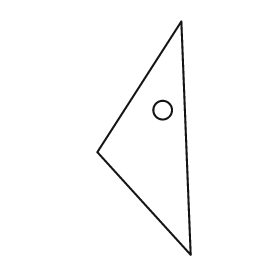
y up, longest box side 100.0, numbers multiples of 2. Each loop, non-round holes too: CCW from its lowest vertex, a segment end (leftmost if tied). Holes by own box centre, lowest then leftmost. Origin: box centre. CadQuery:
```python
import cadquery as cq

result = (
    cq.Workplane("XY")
    .moveTo(20.0, -50.0)
    .lineTo(16.0, 50.0)
    .lineTo(-20.0, -6.0)
    .close()
    .moveTo(8.0, 12.0)
    .circle(4.0)
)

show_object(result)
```